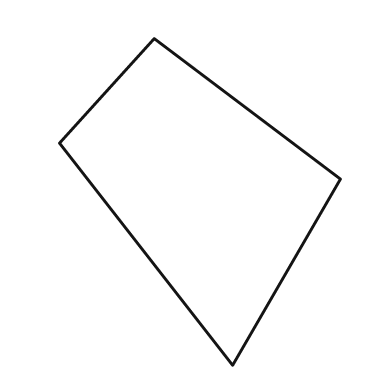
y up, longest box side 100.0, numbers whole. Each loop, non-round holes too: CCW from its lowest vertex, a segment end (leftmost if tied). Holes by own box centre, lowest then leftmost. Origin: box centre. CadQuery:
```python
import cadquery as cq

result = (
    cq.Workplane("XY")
    .moveTo(10.0, -50.0)
    .lineTo(43.0, 7.0)
    .lineTo(-14.0, 50.0)
    .lineTo(-43.0, 18.0)
    .close()
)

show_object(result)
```